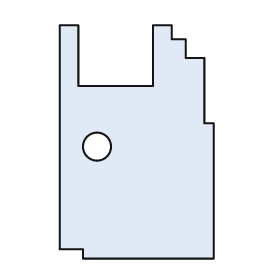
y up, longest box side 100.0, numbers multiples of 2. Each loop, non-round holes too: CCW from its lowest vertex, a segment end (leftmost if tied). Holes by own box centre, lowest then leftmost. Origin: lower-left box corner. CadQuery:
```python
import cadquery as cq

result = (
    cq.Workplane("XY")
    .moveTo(10.0, 0.0)
    .lineTo(66.0, 0.0)
    .lineTo(66.0, 58.0)
    .lineTo(62.0, 58.0)
    .lineTo(62.0, 86.0)
    .lineTo(54.0, 86.0)
    .lineTo(54.0, 94.0)
    .lineTo(48.0, 94.0)
    .lineTo(48.0, 100.0)
    .lineTo(40.0, 100.0)
    .lineTo(40.0, 74.0)
    .lineTo(8.0, 74.0)
    .lineTo(8.0, 100.0)
    .lineTo(0.0, 100.0)
    .lineTo(0.0, 4.0)
    .lineTo(10.0, 4.0)
    .close()
    .moveTo(16.0, 48.0)
    .circle(6.0)
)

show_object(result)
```